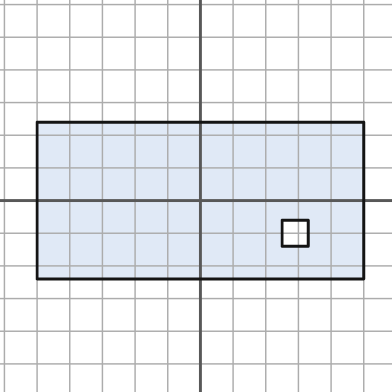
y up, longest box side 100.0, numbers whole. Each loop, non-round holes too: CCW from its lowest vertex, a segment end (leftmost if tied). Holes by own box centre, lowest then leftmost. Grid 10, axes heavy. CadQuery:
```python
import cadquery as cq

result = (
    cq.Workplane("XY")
    .moveTo(-50.0, -24.0)
    .lineTo(50.0, -24.0)
    .lineTo(50.0, 24.0)
    .lineTo(-50.0, 24.0)
    .close()
    .moveTo(25.0, -14.0)
    .lineTo(33.0, -14.0)
    .lineTo(33.0, -6.0)
    .lineTo(25.0, -6.0)
    .close()
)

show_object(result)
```